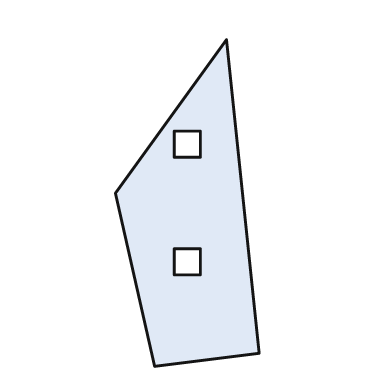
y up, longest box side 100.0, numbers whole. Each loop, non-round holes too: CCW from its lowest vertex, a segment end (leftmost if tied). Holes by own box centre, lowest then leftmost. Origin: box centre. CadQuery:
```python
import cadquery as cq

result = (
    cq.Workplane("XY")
    .moveTo(-10.0, -50.0)
    .lineTo(22.0, -46.0)
    .lineTo(12.0, 50.0)
    .lineTo(-22.0, 3.0)
    .close()
    .moveTo(-4.0, -22.0)
    .lineTo(4.0, -22.0)
    .lineTo(4.0, -14.0)
    .lineTo(-4.0, -14.0)
    .close()
    .moveTo(-4.0, 14.0)
    .lineTo(4.0, 14.0)
    .lineTo(4.0, 22.0)
    .lineTo(-4.0, 22.0)
    .close()
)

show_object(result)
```